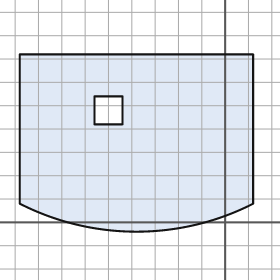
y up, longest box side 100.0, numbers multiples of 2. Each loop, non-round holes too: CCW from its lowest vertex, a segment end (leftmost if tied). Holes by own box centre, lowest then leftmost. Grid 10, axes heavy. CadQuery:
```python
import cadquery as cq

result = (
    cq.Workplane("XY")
    .moveTo(-88.0, 8.0)
    .threePointArc((-38.0, -4.0), (12.0, 8.0))
    .lineTo(12.0, 72.0)
    .lineTo(-88.0, 72.0)
    .close()
    .moveTo(-56.0, 42.0)
    .lineTo(-44.0, 42.0)
    .lineTo(-44.0, 54.0)
    .lineTo(-56.0, 54.0)
    .close()
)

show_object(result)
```